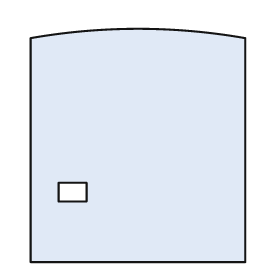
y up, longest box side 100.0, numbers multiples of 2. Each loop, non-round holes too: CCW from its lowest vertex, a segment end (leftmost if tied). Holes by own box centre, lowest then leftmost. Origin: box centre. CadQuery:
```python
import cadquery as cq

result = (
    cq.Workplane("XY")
    .moveTo(-46.0, -50.0)
    .lineTo(46.0, -50.0)
    .lineTo(46.0, 46.0)
    .threePointArc((0.0, 50.0), (-46.0, 46.0))
    .close()
    .moveTo(-34.0, -24.0)
    .lineTo(-22.0, -24.0)
    .lineTo(-22.0, -16.0)
    .lineTo(-34.0, -16.0)
    .close()
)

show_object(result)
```